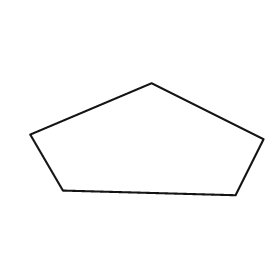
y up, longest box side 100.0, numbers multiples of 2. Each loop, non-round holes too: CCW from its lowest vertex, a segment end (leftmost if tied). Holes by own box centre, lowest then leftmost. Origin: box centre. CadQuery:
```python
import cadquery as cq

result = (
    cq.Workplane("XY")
    .moveTo(38.0, -24.0)
    .lineTo(50.0, 0.0)
    .lineTo(2.0, 24.0)
    .lineTo(-50.0, 2.0)
    .lineTo(-36.0, -22.0)
    .close()
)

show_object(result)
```